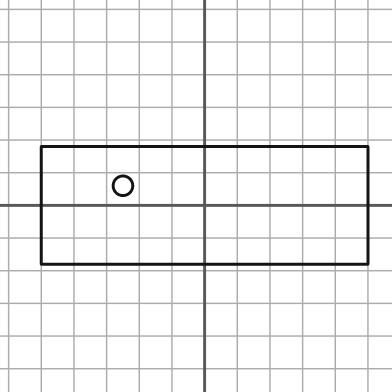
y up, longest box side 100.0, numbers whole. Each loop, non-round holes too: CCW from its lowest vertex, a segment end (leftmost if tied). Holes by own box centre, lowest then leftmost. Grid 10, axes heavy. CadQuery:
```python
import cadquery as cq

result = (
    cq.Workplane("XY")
    .moveTo(-50.0, -18.0)
    .lineTo(50.0, -18.0)
    .lineTo(50.0, 18.0)
    .lineTo(-50.0, 18.0)
    .close()
    .moveTo(-25.0, 6.0)
    .circle(3.0)
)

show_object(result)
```